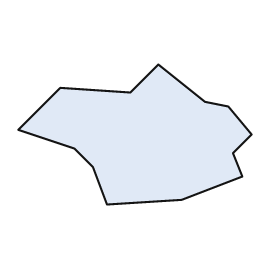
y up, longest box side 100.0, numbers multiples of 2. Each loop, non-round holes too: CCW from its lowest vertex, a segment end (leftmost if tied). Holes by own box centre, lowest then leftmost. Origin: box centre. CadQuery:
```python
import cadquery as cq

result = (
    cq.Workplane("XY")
    .moveTo(-12.0, -30.0)
    .lineTo(20.0, -28.0)
    .lineTo(46.0, -18.0)
    .lineTo(42.0, -8.0)
    .lineTo(50.0, 0.0)
    .lineTo(40.0, 12.0)
    .lineTo(30.0, 14.0)
    .lineTo(10.0, 30.0)
    .lineTo(-2.0, 18.0)
    .lineTo(-32.0, 20.0)
    .lineTo(-50.0, 2.0)
    .lineTo(-26.0, -6.0)
    .lineTo(-18.0, -14.0)
    .close()
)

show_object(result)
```